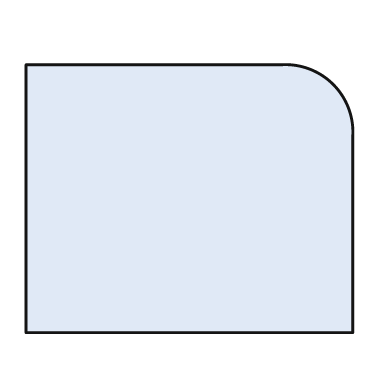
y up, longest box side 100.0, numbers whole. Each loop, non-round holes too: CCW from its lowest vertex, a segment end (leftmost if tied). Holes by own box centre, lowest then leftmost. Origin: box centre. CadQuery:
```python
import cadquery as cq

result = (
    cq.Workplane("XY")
    .moveTo(-50.0, -41.0)
    .lineTo(50.0, -41.0)
    .lineTo(50.0, 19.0)
    .threePointArc((44.0, 35.0), (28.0, 41.0))
    .lineTo(-50.0, 41.0)
    .close()
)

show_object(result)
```